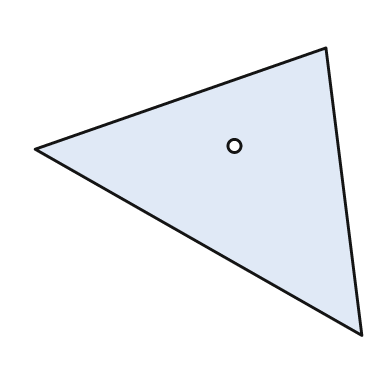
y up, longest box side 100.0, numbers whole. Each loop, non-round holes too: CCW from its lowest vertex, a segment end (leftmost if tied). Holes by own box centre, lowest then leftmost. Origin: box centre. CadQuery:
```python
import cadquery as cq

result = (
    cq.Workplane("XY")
    .moveTo(50.0, -44.0)
    .lineTo(39.0, 44.0)
    .lineTo(-50.0, 13.0)
    .close()
    .moveTo(11.0, 14.0)
    .circle(2.0)
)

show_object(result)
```